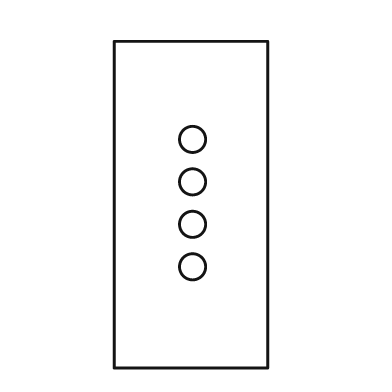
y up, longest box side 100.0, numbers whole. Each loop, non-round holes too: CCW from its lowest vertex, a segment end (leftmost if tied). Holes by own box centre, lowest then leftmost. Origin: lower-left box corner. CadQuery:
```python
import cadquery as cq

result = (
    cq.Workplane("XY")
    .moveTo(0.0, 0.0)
    .lineTo(47.0, 0.0)
    .lineTo(47.0, 100.0)
    .lineTo(0.0, 100.0)
    .close()
    .moveTo(24.0, 31.0)
    .circle(4.0)
    .moveTo(24.0, 44.0)
    .circle(4.0)
    .moveTo(24.0, 57.0)
    .circle(4.0)
    .moveTo(24.0, 70.0)
    .circle(4.0)
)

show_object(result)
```